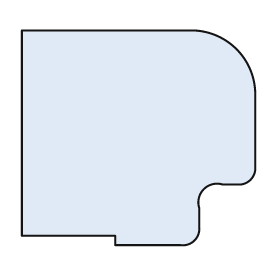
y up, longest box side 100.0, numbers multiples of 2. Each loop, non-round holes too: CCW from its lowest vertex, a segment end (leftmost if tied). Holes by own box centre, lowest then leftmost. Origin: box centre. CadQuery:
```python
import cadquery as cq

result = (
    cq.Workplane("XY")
    .moveTo(-10.0, -46.0)
    .lineTo(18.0, -46.0)
    .threePointArc((24.0, -44.0), (26.0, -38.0))
    .lineTo(26.0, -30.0)
    .threePointArc((28.0, -22.0), (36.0, -20.0))
    .lineTo(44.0, -20.0)
    .threePointArc((48.0, -18.0), (50.0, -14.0))
    .lineTo(50.0, 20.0)
    .threePointArc((42.0, 38.0), (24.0, 46.0))
    .lineTo(-50.0, 46.0)
    .lineTo(-50.0, -42.0)
    .lineTo(-10.0, -42.0)
    .close()
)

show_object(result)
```